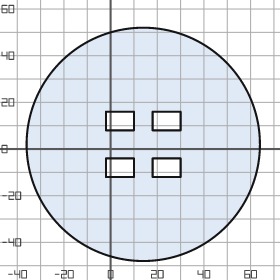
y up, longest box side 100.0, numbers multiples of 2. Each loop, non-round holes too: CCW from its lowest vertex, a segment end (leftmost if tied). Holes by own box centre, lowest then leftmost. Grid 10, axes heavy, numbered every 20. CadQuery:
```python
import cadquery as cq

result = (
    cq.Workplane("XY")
    .moveTo(14.0, 2.0)
    .circle(50.0)
    .moveTo(-2.0, -12.0)
    .lineTo(10.0, -12.0)
    .lineTo(10.0, -4.0)
    .lineTo(-2.0, -4.0)
    .close()
    .moveTo(18.0, -12.0)
    .lineTo(30.0, -12.0)
    .lineTo(30.0, -4.0)
    .lineTo(18.0, -4.0)
    .close()
    .moveTo(-2.0, 8.0)
    .lineTo(10.0, 8.0)
    .lineTo(10.0, 16.0)
    .lineTo(-2.0, 16.0)
    .close()
    .moveTo(18.0, 8.0)
    .lineTo(30.0, 8.0)
    .lineTo(30.0, 16.0)
    .lineTo(18.0, 16.0)
    .close()
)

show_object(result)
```